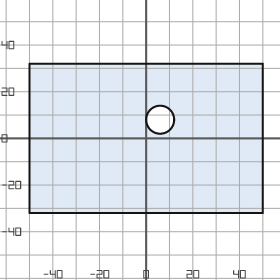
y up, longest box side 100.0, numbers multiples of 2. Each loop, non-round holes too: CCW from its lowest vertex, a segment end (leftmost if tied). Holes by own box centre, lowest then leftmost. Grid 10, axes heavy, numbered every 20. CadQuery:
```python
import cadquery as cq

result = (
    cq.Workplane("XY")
    .moveTo(-50.0, -32.0)
    .lineTo(50.0, -32.0)
    .lineTo(50.0, 32.0)
    .lineTo(-50.0, 32.0)
    .close()
    .moveTo(6.0, 8.0)
    .circle(6.0)
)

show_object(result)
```